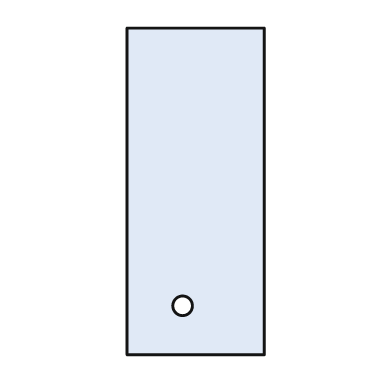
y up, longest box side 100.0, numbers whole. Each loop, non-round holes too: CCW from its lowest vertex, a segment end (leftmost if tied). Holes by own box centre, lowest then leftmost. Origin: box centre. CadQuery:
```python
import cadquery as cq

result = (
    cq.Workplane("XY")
    .moveTo(-21.0, -50.0)
    .lineTo(21.0, -50.0)
    .lineTo(21.0, 50.0)
    .lineTo(-21.0, 50.0)
    .close()
    .moveTo(-4.0, -35.0)
    .circle(3.0)
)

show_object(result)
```